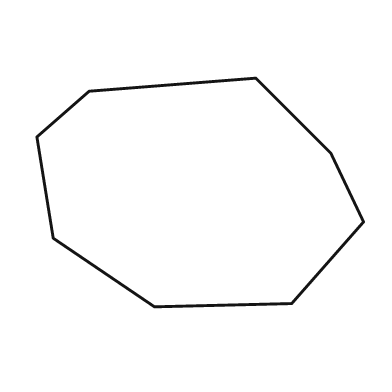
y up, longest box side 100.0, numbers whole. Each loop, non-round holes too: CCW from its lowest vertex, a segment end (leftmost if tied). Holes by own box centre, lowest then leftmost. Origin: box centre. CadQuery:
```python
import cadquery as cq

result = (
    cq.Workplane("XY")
    .moveTo(-14.0, -35.0)
    .lineTo(28.0, -34.0)
    .lineTo(50.0, -9.0)
    .lineTo(40.0, 12.0)
    .lineTo(17.0, 35.0)
    .lineTo(-34.0, 31.0)
    .lineTo(-50.0, 17.0)
    .lineTo(-45.0, -14.0)
    .close()
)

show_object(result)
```